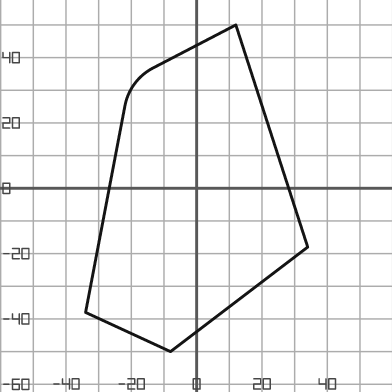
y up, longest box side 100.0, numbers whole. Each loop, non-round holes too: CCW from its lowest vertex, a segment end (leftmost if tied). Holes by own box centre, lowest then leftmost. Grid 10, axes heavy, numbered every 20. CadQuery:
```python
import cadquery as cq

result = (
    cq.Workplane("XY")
    .moveTo(-8.0, -50.0)
    .lineTo(34.0, -18.0)
    .lineTo(12.0, 50.0)
    .lineTo(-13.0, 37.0)
    .threePointArc((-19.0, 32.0), (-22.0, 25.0))
    .lineTo(-34.0, -38.0)
    .close()
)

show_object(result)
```